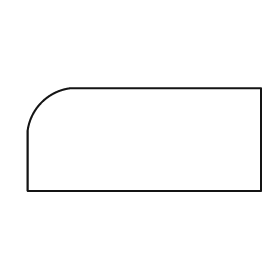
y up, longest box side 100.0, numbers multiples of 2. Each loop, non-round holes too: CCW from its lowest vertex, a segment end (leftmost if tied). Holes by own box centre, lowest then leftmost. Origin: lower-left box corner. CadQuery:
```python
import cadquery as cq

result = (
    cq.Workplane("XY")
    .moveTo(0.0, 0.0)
    .lineTo(100.0, 0.0)
    .lineTo(100.0, 44.0)
    .lineTo(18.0, 44.0)
    .threePointArc((6.0, 38.0), (0.0, 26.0))
    .close()
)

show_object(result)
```